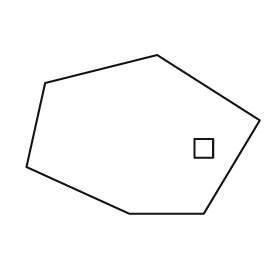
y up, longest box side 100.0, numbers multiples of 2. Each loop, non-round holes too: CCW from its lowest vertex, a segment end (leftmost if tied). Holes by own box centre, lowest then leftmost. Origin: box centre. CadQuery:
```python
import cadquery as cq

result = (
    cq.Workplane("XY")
    .moveTo(-6.0, -34.0)
    .lineTo(26.0, -34.0)
    .lineTo(50.0, 6.0)
    .lineTo(6.0, 34.0)
    .lineTo(-42.0, 22.0)
    .lineTo(-50.0, -14.0)
    .close()
    .moveTo(22.0, -10.0)
    .lineTo(30.0, -10.0)
    .lineTo(30.0, -2.0)
    .lineTo(22.0, -2.0)
    .close()
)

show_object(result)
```